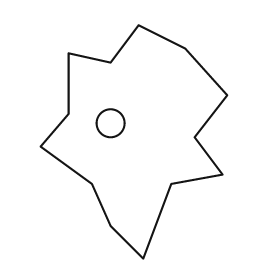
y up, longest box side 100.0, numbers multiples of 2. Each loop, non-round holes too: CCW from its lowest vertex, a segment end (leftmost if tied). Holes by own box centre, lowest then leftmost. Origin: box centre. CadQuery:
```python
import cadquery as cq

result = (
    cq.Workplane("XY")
    .moveTo(4.0, -50.0)
    .lineTo(16.0, -18.0)
    .lineTo(38.0, -14.0)
    .lineTo(26.0, 2.0)
    .lineTo(40.0, 20.0)
    .lineTo(22.0, 40.0)
    .lineTo(2.0, 50.0)
    .lineTo(-10.0, 34.0)
    .lineTo(-28.0, 38.0)
    .lineTo(-28.0, 12.0)
    .lineTo(-40.0, -2.0)
    .lineTo(-18.0, -18.0)
    .lineTo(-10.0, -36.0)
    .close()
    .moveTo(-10.0, 8.0)
    .circle(6.0)
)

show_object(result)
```